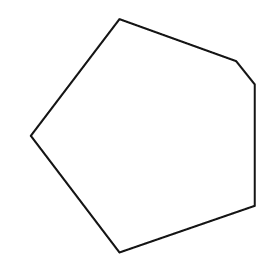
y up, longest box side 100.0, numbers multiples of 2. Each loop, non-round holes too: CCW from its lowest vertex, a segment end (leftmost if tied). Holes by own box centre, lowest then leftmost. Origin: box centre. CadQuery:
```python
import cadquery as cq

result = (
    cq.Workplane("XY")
    .moveTo(-10.0, -50.0)
    .lineTo(48.0, -30.0)
    .lineTo(48.0, 22.0)
    .lineTo(40.0, 32.0)
    .lineTo(-10.0, 50.0)
    .lineTo(-48.0, 0.0)
    .close()
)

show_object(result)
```